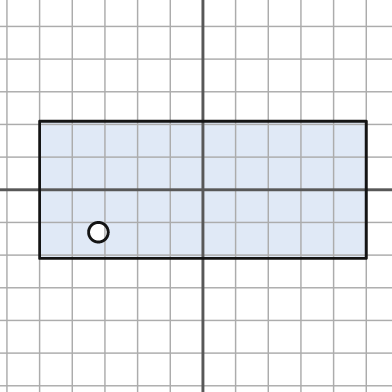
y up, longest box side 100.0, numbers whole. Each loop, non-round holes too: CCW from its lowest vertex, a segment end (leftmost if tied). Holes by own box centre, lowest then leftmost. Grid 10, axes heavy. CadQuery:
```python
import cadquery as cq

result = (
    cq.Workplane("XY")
    .moveTo(-50.0, -21.0)
    .lineTo(50.0, -21.0)
    .lineTo(50.0, 21.0)
    .lineTo(-50.0, 21.0)
    .close()
    .moveTo(-32.0, -13.0)
    .circle(3.0)
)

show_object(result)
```